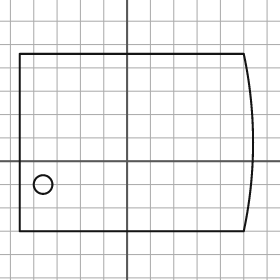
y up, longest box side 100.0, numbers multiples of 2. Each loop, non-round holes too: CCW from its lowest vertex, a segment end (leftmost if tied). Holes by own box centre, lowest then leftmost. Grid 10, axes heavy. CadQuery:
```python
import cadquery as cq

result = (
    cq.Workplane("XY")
    .moveTo(-46.0, -30.0)
    .lineTo(50.0, -30.0)
    .threePointArc((54.0, 8.0), (50.0, 46.0))
    .lineTo(-46.0, 46.0)
    .close()
    .moveTo(-36.0, -10.0)
    .circle(4.0)
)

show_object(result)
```